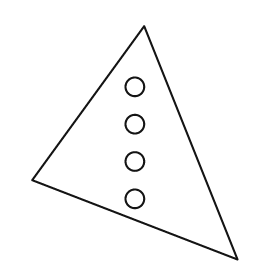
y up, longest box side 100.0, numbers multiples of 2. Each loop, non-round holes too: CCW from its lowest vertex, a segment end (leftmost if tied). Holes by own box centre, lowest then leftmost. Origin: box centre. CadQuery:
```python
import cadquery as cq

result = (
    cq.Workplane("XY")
    .moveTo(44.0, -50.0)
    .lineTo(4.0, 50.0)
    .lineTo(-44.0, -16.0)
    .close()
    .moveTo(0.0, -24.0)
    .circle(4.0)
    .moveTo(0.0, -8.0)
    .circle(4.0)
    .moveTo(0.0, 8.0)
    .circle(4.0)
    .moveTo(0.0, 24.0)
    .circle(4.0)
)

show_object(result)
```